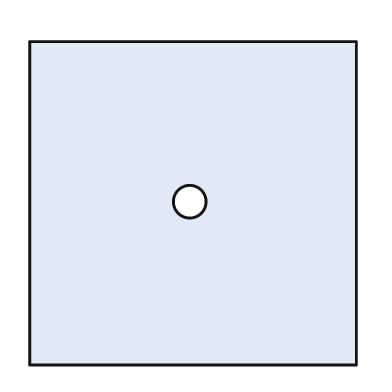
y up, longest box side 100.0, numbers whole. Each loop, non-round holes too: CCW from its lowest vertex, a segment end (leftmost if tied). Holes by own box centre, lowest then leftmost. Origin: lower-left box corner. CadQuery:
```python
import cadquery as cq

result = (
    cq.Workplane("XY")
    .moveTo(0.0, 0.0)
    .lineTo(100.0, 0.0)
    .lineTo(100.0, 99.0)
    .lineTo(0.0, 99.0)
    .close()
    .moveTo(49.0, 50.0)
    .circle(5.0)
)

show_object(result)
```